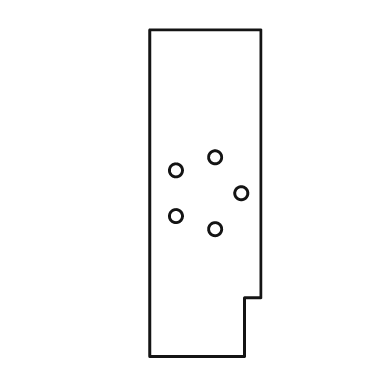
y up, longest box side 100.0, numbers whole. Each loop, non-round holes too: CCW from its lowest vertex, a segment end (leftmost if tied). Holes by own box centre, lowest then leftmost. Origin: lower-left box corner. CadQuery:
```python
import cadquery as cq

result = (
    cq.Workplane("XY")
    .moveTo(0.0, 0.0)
    .lineTo(29.0, 0.0)
    .lineTo(29.0, 18.0)
    .lineTo(34.0, 18.0)
    .lineTo(34.0, 100.0)
    .lineTo(0.0, 100.0)
    .close()
    .moveTo(20.0, 39.0)
    .circle(2.0)
    .moveTo(8.0, 43.0)
    .circle(2.0)
    .moveTo(28.0, 50.0)
    .circle(2.0)
    .moveTo(8.0, 57.0)
    .circle(2.0)
    .moveTo(20.0, 61.0)
    .circle(2.0)
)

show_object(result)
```